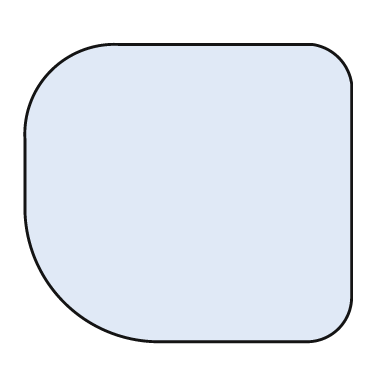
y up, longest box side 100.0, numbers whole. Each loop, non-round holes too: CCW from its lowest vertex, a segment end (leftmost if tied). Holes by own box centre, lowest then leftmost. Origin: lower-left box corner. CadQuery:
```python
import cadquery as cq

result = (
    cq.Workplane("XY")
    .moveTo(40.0, 0.0)
    .lineTo(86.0, 0.0)
    .threePointArc((96.0, 4.0), (100.0, 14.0))
    .lineTo(100.0, 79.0)
    .threePointArc((96.0, 87.0), (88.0, 91.0))
    .lineTo(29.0, 91.0)
    .threePointArc((8.0, 83.0), (0.0, 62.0))
    .lineTo(0.0, 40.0)
    .threePointArc((12.0, 12.0), (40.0, 0.0))
    .close()
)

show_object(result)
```